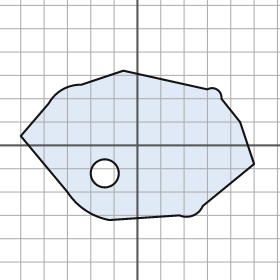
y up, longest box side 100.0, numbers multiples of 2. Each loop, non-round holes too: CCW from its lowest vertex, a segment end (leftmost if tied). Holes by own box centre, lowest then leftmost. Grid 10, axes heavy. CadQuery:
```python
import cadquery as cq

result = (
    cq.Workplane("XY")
    .moveTo(-12.0, -32.0)
    .lineTo(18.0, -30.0)
    .threePointArc((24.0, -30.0), (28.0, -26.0))
    .lineTo(50.0, -8.0)
    .lineTo(44.0, 10.0)
    .lineTo(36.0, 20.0)
    .threePointArc((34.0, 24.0), (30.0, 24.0))
    .lineTo(-6.0, 32.0)
    .lineTo(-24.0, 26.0)
    .threePointArc((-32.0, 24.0), (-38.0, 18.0))
    .lineTo(-50.0, 4.0)
    .lineTo(-30.0, -20.0)
    .threePointArc((-22.0, -28.0), (-12.0, -32.0))
    .close()
    .moveTo(-14.0, -12.0)
    .circle(6.0)
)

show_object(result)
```